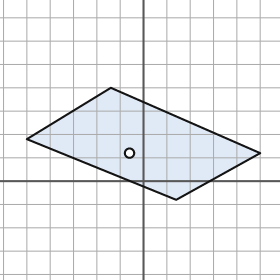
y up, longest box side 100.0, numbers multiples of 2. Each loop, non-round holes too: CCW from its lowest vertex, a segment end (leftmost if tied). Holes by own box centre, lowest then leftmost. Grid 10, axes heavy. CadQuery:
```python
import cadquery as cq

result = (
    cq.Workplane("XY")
    .moveTo(14.0, -8.0)
    .lineTo(50.0, 12.0)
    .lineTo(-14.0, 40.0)
    .lineTo(-50.0, 18.0)
    .close()
    .moveTo(-6.0, 12.0)
    .circle(2.0)
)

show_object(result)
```